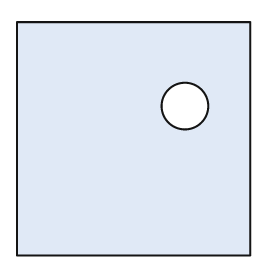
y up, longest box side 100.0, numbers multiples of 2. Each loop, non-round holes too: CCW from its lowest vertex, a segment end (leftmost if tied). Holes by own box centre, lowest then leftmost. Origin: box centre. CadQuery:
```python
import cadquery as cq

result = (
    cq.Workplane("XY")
    .moveTo(-50.0, -50.0)
    .lineTo(50.0, -50.0)
    .lineTo(50.0, 50.0)
    .lineTo(-50.0, 50.0)
    .close()
    .moveTo(22.0, 14.0)
    .circle(10.0)
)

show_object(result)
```